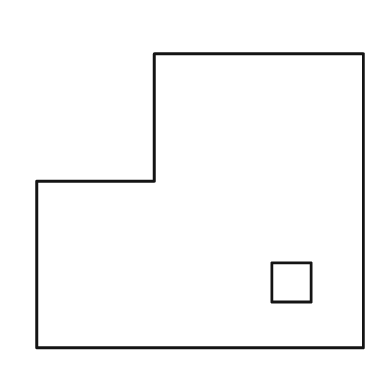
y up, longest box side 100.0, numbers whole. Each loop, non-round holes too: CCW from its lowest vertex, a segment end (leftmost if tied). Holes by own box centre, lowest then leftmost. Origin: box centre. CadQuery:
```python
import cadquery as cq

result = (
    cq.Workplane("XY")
    .moveTo(-50.0, -45.0)
    .lineTo(50.0, -45.0)
    .lineTo(50.0, 45.0)
    .lineTo(-14.0, 45.0)
    .lineTo(-14.0, 6.0)
    .lineTo(-50.0, 6.0)
    .close()
    .moveTo(22.0, -31.0)
    .lineTo(34.0, -31.0)
    .lineTo(34.0, -19.0)
    .lineTo(22.0, -19.0)
    .close()
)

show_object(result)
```